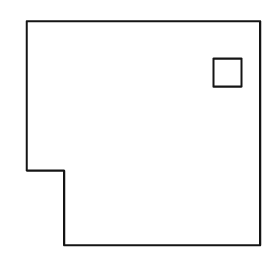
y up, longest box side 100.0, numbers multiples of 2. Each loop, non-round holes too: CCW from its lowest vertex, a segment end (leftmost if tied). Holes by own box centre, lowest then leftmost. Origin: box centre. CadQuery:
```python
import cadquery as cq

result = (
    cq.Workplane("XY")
    .moveTo(-34.0, -48.0)
    .lineTo(50.0, -48.0)
    .lineTo(50.0, 48.0)
    .lineTo(-50.0, 48.0)
    .lineTo(-50.0, -16.0)
    .lineTo(-34.0, -16.0)
    .close()
    .moveTo(30.0, 20.0)
    .lineTo(42.0, 20.0)
    .lineTo(42.0, 32.0)
    .lineTo(30.0, 32.0)
    .close()
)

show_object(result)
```